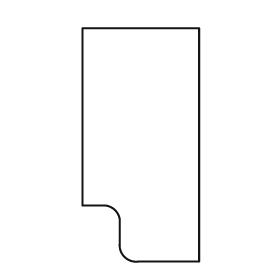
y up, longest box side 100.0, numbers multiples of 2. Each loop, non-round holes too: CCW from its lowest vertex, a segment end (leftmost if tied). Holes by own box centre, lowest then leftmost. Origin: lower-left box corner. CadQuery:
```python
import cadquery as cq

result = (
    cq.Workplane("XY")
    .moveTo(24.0, 0.0)
    .lineTo(50.0, 0.0)
    .lineTo(50.0, 100.0)
    .lineTo(0.0, 100.0)
    .lineTo(0.0, 24.0)
    .lineTo(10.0, 24.0)
    .threePointArc((14.0, 22.0), (16.0, 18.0))
    .lineTo(16.0, 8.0)
    .threePointArc((18.0, 2.0), (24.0, 0.0))
    .close()
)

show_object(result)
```